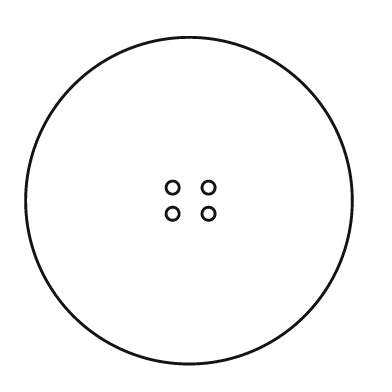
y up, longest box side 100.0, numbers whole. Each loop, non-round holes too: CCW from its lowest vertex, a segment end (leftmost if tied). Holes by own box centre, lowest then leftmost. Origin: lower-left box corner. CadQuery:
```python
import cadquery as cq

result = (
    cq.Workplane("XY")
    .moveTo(50.0, 50.0)
    .circle(50.0)
    .moveTo(45.0, 46.0)
    .circle(2.0)
    .moveTo(56.0, 46.0)
    .circle(2.0)
    .moveTo(45.0, 54.0)
    .circle(2.0)
    .moveTo(56.0, 54.0)
    .circle(2.0)
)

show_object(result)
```